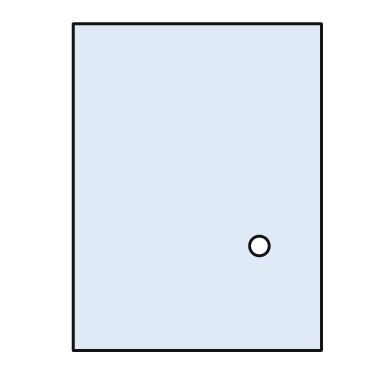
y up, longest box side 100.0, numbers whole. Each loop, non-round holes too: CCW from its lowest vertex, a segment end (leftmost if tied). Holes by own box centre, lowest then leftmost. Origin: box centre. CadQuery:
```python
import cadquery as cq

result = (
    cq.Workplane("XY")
    .moveTo(-38.0, -50.0)
    .lineTo(38.0, -50.0)
    .lineTo(38.0, 50.0)
    .lineTo(-38.0, 50.0)
    .close()
    .moveTo(19.0, -18.0)
    .circle(3.0)
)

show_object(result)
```